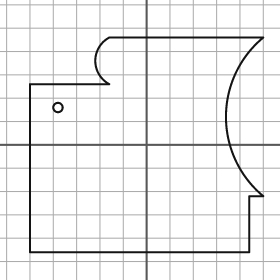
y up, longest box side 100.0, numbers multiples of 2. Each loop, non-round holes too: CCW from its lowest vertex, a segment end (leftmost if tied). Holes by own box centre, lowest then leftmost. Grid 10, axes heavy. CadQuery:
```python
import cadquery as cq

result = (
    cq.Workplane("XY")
    .moveTo(-50.0, -46.0)
    .lineTo(44.0, -46.0)
    .lineTo(44.0, -22.0)
    .lineTo(50.0, -22.0)
    .threePointArc((34.0, 12.0), (50.0, 46.0))
    .lineTo(-16.0, 46.0)
    .threePointArc((-22.0, 36.0), (-16.0, 26.0))
    .lineTo(-50.0, 26.0)
    .close()
    .moveTo(-38.0, 16.0)
    .circle(2.0)
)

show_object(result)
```